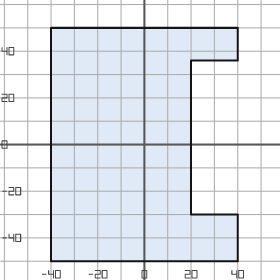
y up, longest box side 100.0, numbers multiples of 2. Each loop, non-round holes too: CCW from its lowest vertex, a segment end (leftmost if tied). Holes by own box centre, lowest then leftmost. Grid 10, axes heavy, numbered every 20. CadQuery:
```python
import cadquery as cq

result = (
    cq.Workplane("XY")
    .moveTo(-40.0, -50.0)
    .lineTo(40.0, -50.0)
    .lineTo(40.0, -30.0)
    .lineTo(20.0, -30.0)
    .lineTo(20.0, 36.0)
    .lineTo(40.0, 36.0)
    .lineTo(40.0, 50.0)
    .lineTo(-40.0, 50.0)
    .close()
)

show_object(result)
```